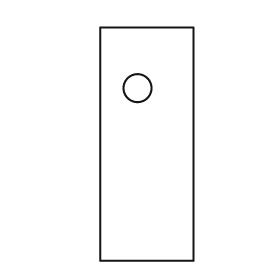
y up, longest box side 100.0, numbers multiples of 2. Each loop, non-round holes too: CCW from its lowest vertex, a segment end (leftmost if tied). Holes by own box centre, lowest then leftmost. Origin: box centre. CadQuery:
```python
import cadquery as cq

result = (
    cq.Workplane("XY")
    .moveTo(-20.0, -50.0)
    .lineTo(20.0, -50.0)
    .lineTo(20.0, 50.0)
    .lineTo(-20.0, 50.0)
    .close()
    .moveTo(-4.0, 24.0)
    .circle(6.0)
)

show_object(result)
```